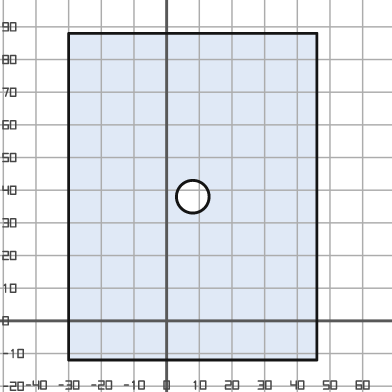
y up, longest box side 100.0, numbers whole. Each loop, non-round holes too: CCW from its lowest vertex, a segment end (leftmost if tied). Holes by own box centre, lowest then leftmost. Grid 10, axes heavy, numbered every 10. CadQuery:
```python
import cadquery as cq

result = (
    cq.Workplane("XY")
    .moveTo(-30.0, -12.0)
    .lineTo(46.0, -12.0)
    .lineTo(46.0, 88.0)
    .lineTo(-30.0, 88.0)
    .close()
    .moveTo(8.0, 38.0)
    .circle(5.0)
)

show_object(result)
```